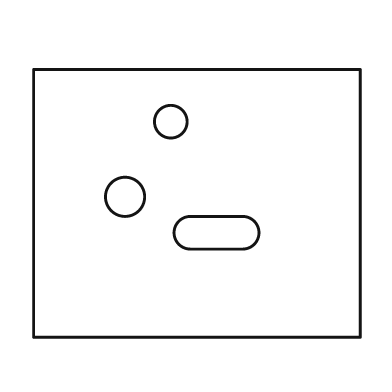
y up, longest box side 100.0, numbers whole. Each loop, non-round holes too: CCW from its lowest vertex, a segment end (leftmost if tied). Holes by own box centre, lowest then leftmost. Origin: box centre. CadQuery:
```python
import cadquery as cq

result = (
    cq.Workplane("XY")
    .moveTo(-50.0, -41.0)
    .lineTo(50.0, -41.0)
    .lineTo(50.0, 41.0)
    .lineTo(-50.0, 41.0)
    .close()
    .moveTo(-2.0, -14.0)
    .lineTo(14.0, -14.0)
    .threePointArc((19.0, -9.0), (14.0, -4.0))
    .lineTo(-2.0, -4.0)
    .threePointArc((-7.0, -9.0), (-2.0, -14.0))
    .close()
    .moveTo(-22.0, 2.0)
    .circle(6.0)
    .moveTo(-8.0, 25.0)
    .circle(5.0)
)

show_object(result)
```